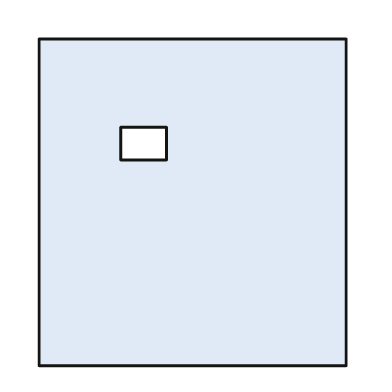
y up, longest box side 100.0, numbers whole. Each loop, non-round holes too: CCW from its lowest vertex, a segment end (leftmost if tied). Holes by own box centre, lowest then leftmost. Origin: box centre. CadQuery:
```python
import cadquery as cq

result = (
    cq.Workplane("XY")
    .moveTo(-47.0, -50.0)
    .lineTo(47.0, -50.0)
    .lineTo(47.0, 50.0)
    .lineTo(-47.0, 50.0)
    .close()
    .moveTo(-22.0, 13.0)
    .lineTo(-8.0, 13.0)
    .lineTo(-8.0, 23.0)
    .lineTo(-22.0, 23.0)
    .close()
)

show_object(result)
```